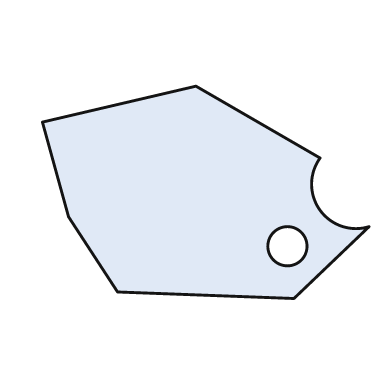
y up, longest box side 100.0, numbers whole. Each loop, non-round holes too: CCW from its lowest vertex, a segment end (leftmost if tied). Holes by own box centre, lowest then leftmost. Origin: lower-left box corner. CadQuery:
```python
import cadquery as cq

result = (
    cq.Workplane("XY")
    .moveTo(77.0, 0.0)
    .lineTo(100.0, 22.0)
    .threePointArc((85.0, 27.0), (85.0, 43.0))
    .lineTo(47.0, 65.0)
    .lineTo(0.0, 54.0)
    .lineTo(8.0, 25.0)
    .lineTo(23.0, 2.0)
    .close()
    .moveTo(75.0, 16.0)
    .circle(6.0)
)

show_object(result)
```